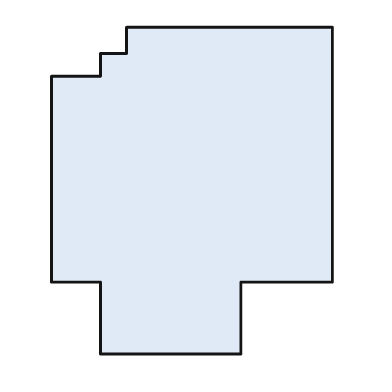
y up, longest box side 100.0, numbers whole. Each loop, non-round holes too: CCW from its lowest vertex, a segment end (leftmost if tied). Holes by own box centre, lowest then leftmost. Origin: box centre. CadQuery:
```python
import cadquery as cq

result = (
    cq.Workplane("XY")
    .moveTo(-28.0, -50.0)
    .lineTo(15.0, -50.0)
    .lineTo(15.0, -28.0)
    .lineTo(43.0, -28.0)
    .lineTo(43.0, 50.0)
    .lineTo(-20.0, 50.0)
    .lineTo(-20.0, 42.0)
    .lineTo(-28.0, 42.0)
    .lineTo(-28.0, 35.0)
    .lineTo(-43.0, 35.0)
    .lineTo(-43.0, -28.0)
    .lineTo(-28.0, -28.0)
    .close()
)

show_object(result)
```